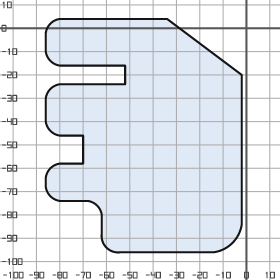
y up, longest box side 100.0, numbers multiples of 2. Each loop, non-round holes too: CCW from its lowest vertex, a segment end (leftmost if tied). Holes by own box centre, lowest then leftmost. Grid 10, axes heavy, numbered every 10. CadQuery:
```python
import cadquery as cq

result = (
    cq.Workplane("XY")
    .moveTo(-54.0, -96.0)
    .lineTo(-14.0, -96.0)
    .threePointArc((-6.0, -92.0), (-2.0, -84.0))
    .lineTo(-2.0, -20.0)
    .lineTo(-34.0, 4.0)
    .lineTo(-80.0, 4.0)
    .threePointArc((-84.0, 2.0), (-86.0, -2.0))
    .lineTo(-86.0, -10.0)
    .threePointArc((-84.0, -14.0), (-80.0, -16.0))
    .lineTo(-52.0, -16.0)
    .lineTo(-52.0, -24.0)
    .lineTo(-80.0, -24.0)
    .threePointArc((-84.0, -26.0), (-86.0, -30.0))
    .lineTo(-86.0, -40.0)
    .threePointArc((-84.0, -44.0), (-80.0, -46.0))
    .lineTo(-70.0, -46.0)
    .lineTo(-70.0, -58.0)
    .lineTo(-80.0, -58.0)
    .threePointArc((-84.0, -60.0), (-86.0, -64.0))
    .lineTo(-86.0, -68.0)
    .threePointArc((-84.0, -72.0), (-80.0, -74.0))
    .lineTo(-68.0, -74.0)
    .threePointArc((-64.0, -76.0), (-62.0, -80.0))
    .lineTo(-62.0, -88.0)
    .threePointArc((-60.0, -94.0), (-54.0, -96.0))
    .close()
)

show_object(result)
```